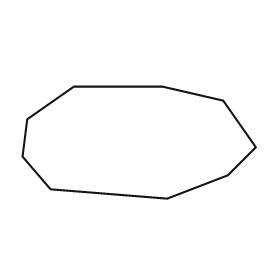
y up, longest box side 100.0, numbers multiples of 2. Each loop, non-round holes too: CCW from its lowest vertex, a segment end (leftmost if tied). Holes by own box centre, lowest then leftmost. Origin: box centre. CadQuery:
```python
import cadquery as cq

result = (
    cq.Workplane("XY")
    .moveTo(12.0, -24.0)
    .lineTo(38.0, -14.0)
    .lineTo(50.0, -2.0)
    .lineTo(36.0, 18.0)
    .lineTo(10.0, 24.0)
    .lineTo(-28.0, 24.0)
    .lineTo(-48.0, 10.0)
    .lineTo(-50.0, -6.0)
    .lineTo(-38.0, -20.0)
    .close()
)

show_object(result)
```